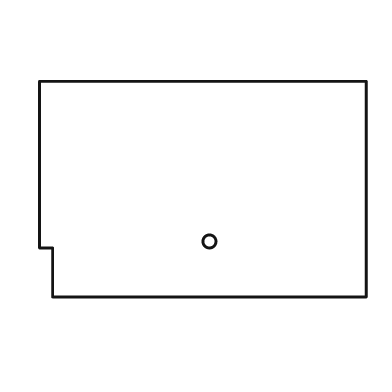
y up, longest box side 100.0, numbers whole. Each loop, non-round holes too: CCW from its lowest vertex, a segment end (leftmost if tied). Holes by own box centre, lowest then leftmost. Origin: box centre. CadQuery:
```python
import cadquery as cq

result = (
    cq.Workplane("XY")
    .moveTo(-46.0, -33.0)
    .lineTo(50.0, -33.0)
    .lineTo(50.0, 33.0)
    .lineTo(-50.0, 33.0)
    .lineTo(-50.0, -18.0)
    .lineTo(-46.0, -18.0)
    .close()
    .moveTo(2.0, -16.0)
    .circle(2.0)
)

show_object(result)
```